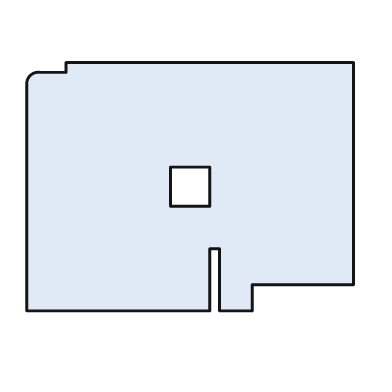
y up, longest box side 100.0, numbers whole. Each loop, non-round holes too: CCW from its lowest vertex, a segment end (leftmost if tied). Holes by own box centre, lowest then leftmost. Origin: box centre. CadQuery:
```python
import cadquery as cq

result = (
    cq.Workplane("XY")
    .moveTo(-50.0, -38.0)
    .lineTo(6.0, -38.0)
    .lineTo(6.0, -19.0)
    .lineTo(9.0, -19.0)
    .lineTo(9.0, -38.0)
    .lineTo(19.0, -38.0)
    .lineTo(19.0, -30.0)
    .lineTo(50.0, -30.0)
    .lineTo(50.0, 38.0)
    .lineTo(-38.0, 38.0)
    .lineTo(-38.0, 35.0)
    .lineTo(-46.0, 35.0)
    .threePointArc((-49.0, 34.0), (-50.0, 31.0))
    .close()
    .moveTo(-6.0, -6.0)
    .lineTo(6.0, -6.0)
    .lineTo(6.0, 6.0)
    .lineTo(-6.0, 6.0)
    .close()
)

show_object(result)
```